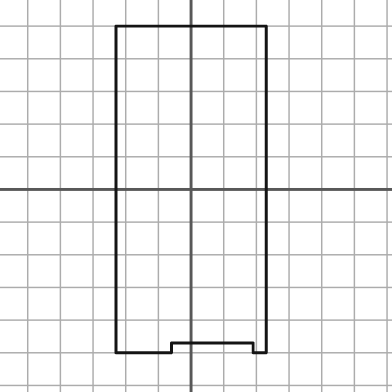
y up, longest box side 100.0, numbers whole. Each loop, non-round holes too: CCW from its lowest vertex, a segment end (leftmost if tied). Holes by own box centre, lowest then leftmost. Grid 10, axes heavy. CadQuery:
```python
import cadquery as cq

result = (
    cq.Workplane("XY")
    .moveTo(-23.0, -50.0)
    .lineTo(-6.0, -50.0)
    .lineTo(-6.0, -47.0)
    .lineTo(19.0, -47.0)
    .lineTo(19.0, -50.0)
    .lineTo(23.0, -50.0)
    .lineTo(23.0, 50.0)
    .lineTo(-23.0, 50.0)
    .close()
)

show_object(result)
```